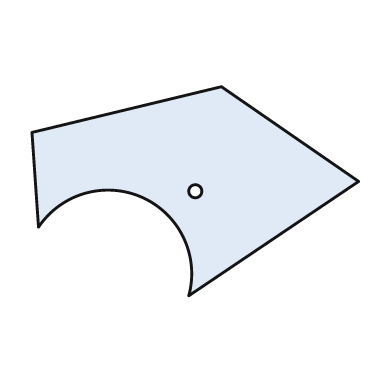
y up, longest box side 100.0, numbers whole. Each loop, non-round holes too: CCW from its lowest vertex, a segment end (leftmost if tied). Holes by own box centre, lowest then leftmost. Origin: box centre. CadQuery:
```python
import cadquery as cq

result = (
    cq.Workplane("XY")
    .moveTo(-2.0, -32.0)
    .lineTo(50.0, 3.0)
    .lineTo(8.0, 32.0)
    .lineTo(-50.0, 18.0)
    .lineTo(-48.0, -11.0)
    .threePointArc((-16.0, -2.0), (-2.0, -32.0))
    .close()
    .moveTo(0.0, 0.0)
    .circle(2.0)
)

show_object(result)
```